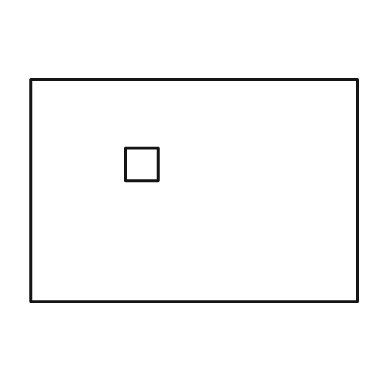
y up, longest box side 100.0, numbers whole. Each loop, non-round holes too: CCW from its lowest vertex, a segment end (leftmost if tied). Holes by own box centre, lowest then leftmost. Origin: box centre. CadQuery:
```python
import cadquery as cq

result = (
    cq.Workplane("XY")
    .moveTo(-50.0, -34.0)
    .lineTo(50.0, -34.0)
    .lineTo(50.0, 34.0)
    .lineTo(-50.0, 34.0)
    .close()
    .moveTo(-21.0, 3.0)
    .lineTo(-11.0, 3.0)
    .lineTo(-11.0, 13.0)
    .lineTo(-21.0, 13.0)
    .close()
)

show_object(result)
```